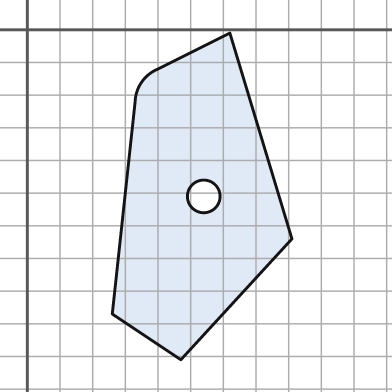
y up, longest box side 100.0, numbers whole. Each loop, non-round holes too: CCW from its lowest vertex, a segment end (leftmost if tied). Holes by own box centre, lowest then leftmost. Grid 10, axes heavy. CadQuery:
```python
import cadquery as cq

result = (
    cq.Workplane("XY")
    .moveTo(47.0, -101.0)
    .lineTo(81.0, -64.0)
    .lineTo(62.0, -1.0)
    .lineTo(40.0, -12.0)
    .threePointArc((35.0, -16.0), (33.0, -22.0))
    .lineTo(26.0, -87.0)
    .close()
    .moveTo(54.0, -51.0)
    .circle(5.0)
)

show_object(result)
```